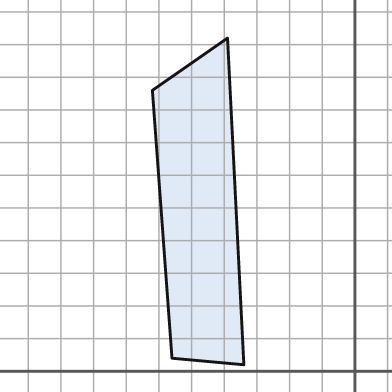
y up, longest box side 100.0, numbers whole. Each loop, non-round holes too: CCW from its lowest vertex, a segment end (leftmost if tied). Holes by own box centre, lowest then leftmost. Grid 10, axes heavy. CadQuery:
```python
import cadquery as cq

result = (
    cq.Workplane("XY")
    .moveTo(-34.0, 2.0)
    .lineTo(-39.0, 102.0)
    .lineTo(-62.0, 86.0)
    .lineTo(-56.0, 4.0)
    .close()
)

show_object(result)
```